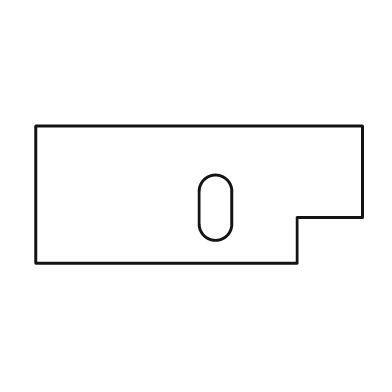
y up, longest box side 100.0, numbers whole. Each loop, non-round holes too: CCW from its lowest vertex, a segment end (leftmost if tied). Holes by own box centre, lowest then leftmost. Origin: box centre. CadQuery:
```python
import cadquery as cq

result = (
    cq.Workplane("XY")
    .moveTo(-50.0, -21.0)
    .lineTo(30.0, -21.0)
    .lineTo(30.0, -7.0)
    .lineTo(50.0, -7.0)
    .lineTo(50.0, 21.0)
    .lineTo(-50.0, 21.0)
    .close()
    .moveTo(0.0, -9.0)
    .threePointArc((5.0, -14.0), (10.0, -9.0))
    .lineTo(10.0, 1.0)
    .threePointArc((5.0, 6.0), (0.0, 1.0))
    .close()
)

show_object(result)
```